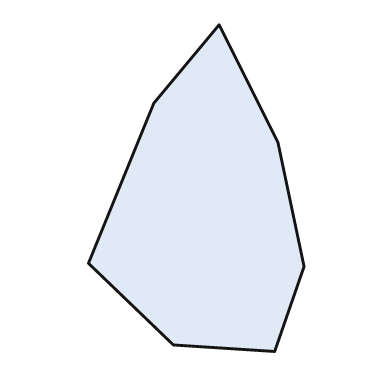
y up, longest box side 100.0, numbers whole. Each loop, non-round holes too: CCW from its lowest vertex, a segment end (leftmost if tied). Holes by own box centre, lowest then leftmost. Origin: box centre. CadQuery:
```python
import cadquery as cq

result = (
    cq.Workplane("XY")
    .moveTo(24.0, -50.0)
    .lineTo(33.0, -24.0)
    .lineTo(25.0, 14.0)
    .lineTo(7.0, 50.0)
    .lineTo(-13.0, 26.0)
    .lineTo(-33.0, -23.0)
    .lineTo(-7.0, -48.0)
    .close()
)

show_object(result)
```